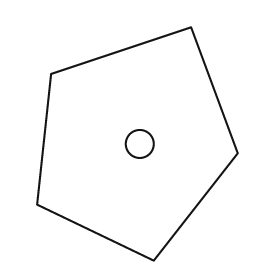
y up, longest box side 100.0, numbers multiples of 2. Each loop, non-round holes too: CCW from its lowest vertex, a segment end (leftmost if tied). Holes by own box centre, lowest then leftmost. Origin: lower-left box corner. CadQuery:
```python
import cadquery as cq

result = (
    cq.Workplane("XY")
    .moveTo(50.0, 0.0)
    .lineTo(86.0, 46.0)
    .lineTo(66.0, 100.0)
    .lineTo(6.0, 80.0)
    .lineTo(0.0, 24.0)
    .close()
    .moveTo(44.0, 50.0)
    .circle(6.0)
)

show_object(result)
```